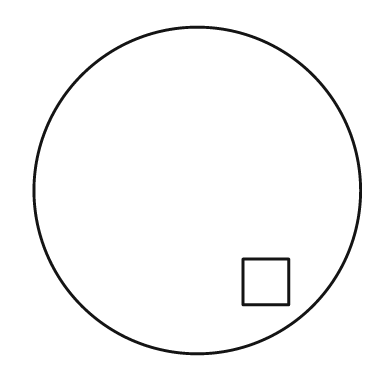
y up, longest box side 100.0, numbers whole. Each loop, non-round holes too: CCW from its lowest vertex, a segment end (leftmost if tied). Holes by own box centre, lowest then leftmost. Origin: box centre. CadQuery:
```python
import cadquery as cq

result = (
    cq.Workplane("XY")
    .moveTo(0.0, 0.0)
    .circle(50.0)
    .moveTo(14.0, -35.0)
    .lineTo(28.0, -35.0)
    .lineTo(28.0, -21.0)
    .lineTo(14.0, -21.0)
    .close()
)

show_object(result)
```